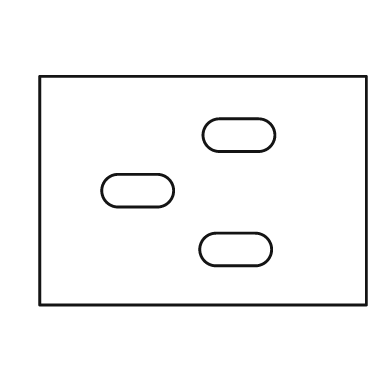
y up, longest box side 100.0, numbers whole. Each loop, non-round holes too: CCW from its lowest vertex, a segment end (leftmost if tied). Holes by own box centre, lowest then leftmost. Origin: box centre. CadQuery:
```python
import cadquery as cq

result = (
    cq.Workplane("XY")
    .moveTo(-50.0, -35.0)
    .lineTo(50.0, -35.0)
    .lineTo(50.0, 35.0)
    .lineTo(-50.0, 35.0)
    .close()
    .moveTo(4.0, -23.0)
    .lineTo(16.0, -23.0)
    .threePointArc((21.0, -18.0), (16.0, -13.0))
    .lineTo(4.0, -13.0)
    .threePointArc((-1.0, -18.0), (4.0, -23.0))
    .close()
    .moveTo(-26.0, -5.0)
    .lineTo(-14.0, -5.0)
    .threePointArc((-9.0, 0.0), (-14.0, 5.0))
    .lineTo(-26.0, 5.0)
    .threePointArc((-31.0, 0.0), (-26.0, -5.0))
    .close()
    .moveTo(5.0, 12.0)
    .lineTo(17.0, 12.0)
    .threePointArc((22.0, 17.0), (17.0, 22.0))
    .lineTo(5.0, 22.0)
    .threePointArc((0.0, 17.0), (5.0, 12.0))
    .close()
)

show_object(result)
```